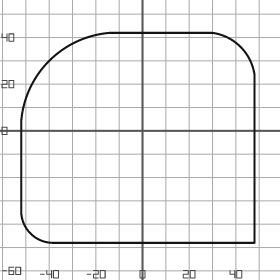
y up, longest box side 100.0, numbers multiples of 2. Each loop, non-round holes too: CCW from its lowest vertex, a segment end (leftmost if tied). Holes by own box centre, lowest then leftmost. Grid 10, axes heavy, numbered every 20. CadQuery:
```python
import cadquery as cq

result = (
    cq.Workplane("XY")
    .moveTo(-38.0, -48.0)
    .lineTo(48.0, -48.0)
    .lineTo(48.0, 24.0)
    .threePointArc((42.0, 36.0), (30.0, 42.0))
    .lineTo(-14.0, 42.0)
    .threePointArc((-40.0, 30.0), (-52.0, 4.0))
    .lineTo(-52.0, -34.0)
    .threePointArc((-48.0, -44.0), (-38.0, -48.0))
    .close()
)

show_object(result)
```